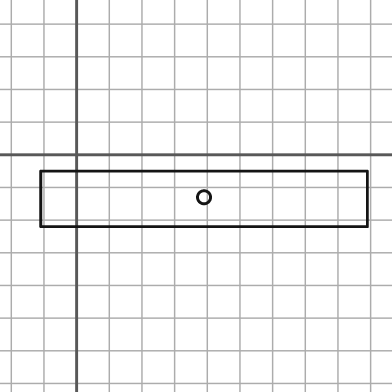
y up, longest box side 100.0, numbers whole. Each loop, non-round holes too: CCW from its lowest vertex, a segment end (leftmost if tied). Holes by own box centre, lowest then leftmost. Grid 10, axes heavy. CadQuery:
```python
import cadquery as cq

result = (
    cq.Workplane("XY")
    .moveTo(-11.0, -22.0)
    .lineTo(89.0, -22.0)
    .lineTo(89.0, -5.0)
    .lineTo(-11.0, -5.0)
    .close()
    .moveTo(39.0, -13.0)
    .circle(2.0)
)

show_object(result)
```